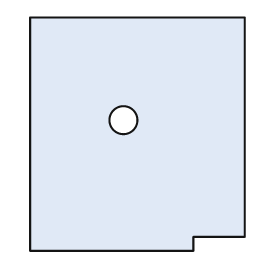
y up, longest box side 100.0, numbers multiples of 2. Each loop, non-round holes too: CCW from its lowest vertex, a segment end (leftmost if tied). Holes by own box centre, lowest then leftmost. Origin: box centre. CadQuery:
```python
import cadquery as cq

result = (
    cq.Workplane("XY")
    .moveTo(-46.0, -50.0)
    .lineTo(24.0, -50.0)
    .lineTo(24.0, -44.0)
    .lineTo(46.0, -44.0)
    .lineTo(46.0, 50.0)
    .lineTo(-46.0, 50.0)
    .close()
    .moveTo(-6.0, 6.0)
    .circle(6.0)
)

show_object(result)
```